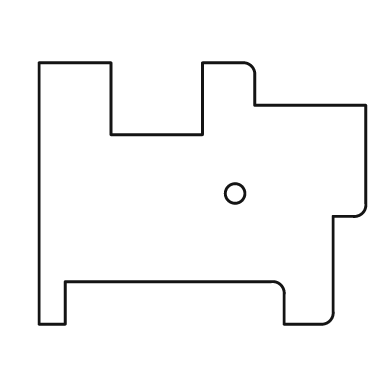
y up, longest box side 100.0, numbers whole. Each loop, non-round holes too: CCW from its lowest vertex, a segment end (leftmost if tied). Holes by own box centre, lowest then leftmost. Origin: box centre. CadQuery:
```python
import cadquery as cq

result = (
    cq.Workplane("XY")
    .moveTo(-50.0, -40.0)
    .lineTo(-42.0, -40.0)
    .lineTo(-42.0, -27.0)
    .lineTo(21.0, -27.0)
    .threePointArc((24.0, -28.0), (25.0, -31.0))
    .lineTo(25.0, -40.0)
    .lineTo(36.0, -40.0)
    .threePointArc((39.0, -39.0), (40.0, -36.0))
    .lineTo(40.0, -7.0)
    .lineTo(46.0, -7.0)
    .threePointArc((49.0, -6.0), (50.0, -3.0))
    .lineTo(50.0, 27.0)
    .lineTo(16.0, 27.0)
    .lineTo(16.0, 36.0)
    .threePointArc((15.0, 39.0), (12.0, 40.0))
    .lineTo(0.0, 40.0)
    .lineTo(0.0, 18.0)
    .lineTo(-28.0, 18.0)
    .lineTo(-28.0, 40.0)
    .lineTo(-50.0, 40.0)
    .close()
    .moveTo(10.0, 0.0)
    .circle(3.0)
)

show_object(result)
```